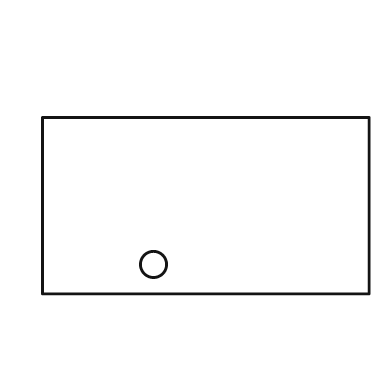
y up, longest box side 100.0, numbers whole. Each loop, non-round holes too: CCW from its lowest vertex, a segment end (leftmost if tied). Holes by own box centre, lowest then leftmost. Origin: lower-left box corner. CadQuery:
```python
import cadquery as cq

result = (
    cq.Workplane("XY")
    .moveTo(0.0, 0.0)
    .lineTo(100.0, 0.0)
    .lineTo(100.0, 54.0)
    .lineTo(0.0, 54.0)
    .close()
    .moveTo(34.0, 9.0)
    .circle(4.0)
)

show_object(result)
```